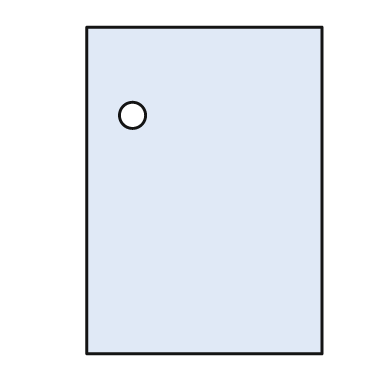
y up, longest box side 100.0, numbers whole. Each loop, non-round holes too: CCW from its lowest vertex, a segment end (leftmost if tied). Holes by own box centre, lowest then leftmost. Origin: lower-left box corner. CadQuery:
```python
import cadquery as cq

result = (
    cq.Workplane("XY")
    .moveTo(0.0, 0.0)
    .lineTo(72.0, 0.0)
    .lineTo(72.0, 100.0)
    .lineTo(0.0, 100.0)
    .close()
    .moveTo(14.0, 73.0)
    .circle(4.0)
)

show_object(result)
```